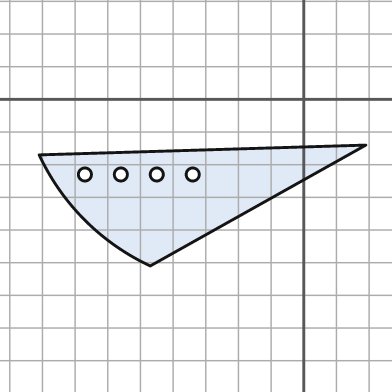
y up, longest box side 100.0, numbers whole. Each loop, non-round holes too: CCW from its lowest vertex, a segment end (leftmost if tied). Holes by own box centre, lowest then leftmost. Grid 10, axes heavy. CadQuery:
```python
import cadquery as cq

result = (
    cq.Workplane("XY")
    .moveTo(-47.0, -51.0)
    .lineTo(19.0, -14.0)
    .lineTo(-81.0, -17.0)
    .threePointArc((-67.0, -37.0), (-47.0, -51.0))
    .close()
    .moveTo(-67.0, -23.0)
    .circle(2.0)
    .moveTo(-56.0, -23.0)
    .circle(2.0)
    .moveTo(-45.0, -23.0)
    .circle(2.0)
    .moveTo(-34.0, -23.0)
    .circle(2.0)
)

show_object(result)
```